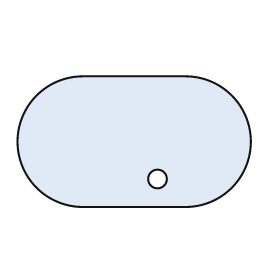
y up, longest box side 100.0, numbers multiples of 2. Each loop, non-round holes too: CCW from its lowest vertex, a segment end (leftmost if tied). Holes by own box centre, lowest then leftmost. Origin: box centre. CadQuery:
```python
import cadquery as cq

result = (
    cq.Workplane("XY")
    .moveTo(-22.0, -28.0)
    .lineTo(22.0, -28.0)
    .threePointArc((50.0, 0.0), (22.0, 28.0))
    .lineTo(-22.0, 28.0)
    .threePointArc((-50.0, 0.0), (-22.0, -28.0))
    .close()
    .moveTo(10.0, -16.0)
    .circle(4.0)
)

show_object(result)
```